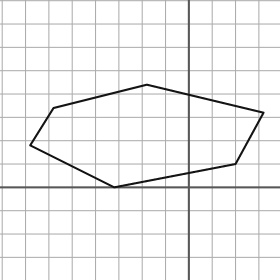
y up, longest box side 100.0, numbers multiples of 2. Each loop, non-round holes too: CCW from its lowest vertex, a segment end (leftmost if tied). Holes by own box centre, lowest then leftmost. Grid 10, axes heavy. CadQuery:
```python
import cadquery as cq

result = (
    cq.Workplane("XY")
    .moveTo(-32.0, 0.0)
    .lineTo(20.0, 10.0)
    .lineTo(32.0, 32.0)
    .lineTo(-18.0, 44.0)
    .lineTo(-58.0, 34.0)
    .lineTo(-68.0, 18.0)
    .close()
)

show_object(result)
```